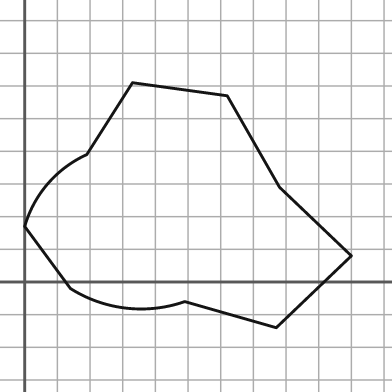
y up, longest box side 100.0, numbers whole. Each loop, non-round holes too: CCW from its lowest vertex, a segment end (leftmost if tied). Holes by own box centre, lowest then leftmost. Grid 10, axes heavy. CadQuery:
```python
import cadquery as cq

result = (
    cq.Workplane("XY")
    .moveTo(77.0, -14.0)
    .lineTo(100.0, 8.0)
    .lineTo(78.0, 29.0)
    .lineTo(62.0, 57.0)
    .lineTo(33.0, 61.0)
    .lineTo(19.0, 39.0)
    .threePointArc((7.0, 30.0), (0.0, 17.0))
    .lineTo(14.0, -2.0)
    .threePointArc((31.0, -8.0), (49.0, -6.0))
    .close()
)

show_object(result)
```